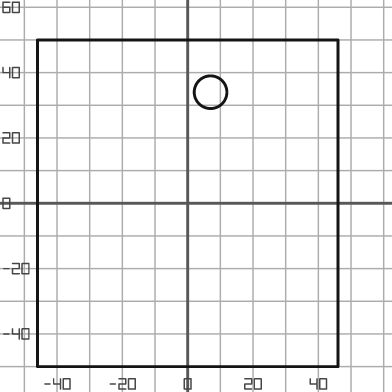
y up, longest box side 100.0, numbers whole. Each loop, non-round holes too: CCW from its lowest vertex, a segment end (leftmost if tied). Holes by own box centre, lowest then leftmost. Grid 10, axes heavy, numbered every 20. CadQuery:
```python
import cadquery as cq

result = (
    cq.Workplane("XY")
    .moveTo(-46.0, -50.0)
    .lineTo(46.0, -50.0)
    .lineTo(46.0, 50.0)
    .lineTo(-46.0, 50.0)
    .close()
    .moveTo(7.0, 34.0)
    .circle(5.0)
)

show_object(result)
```